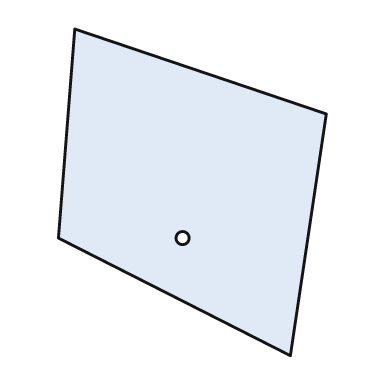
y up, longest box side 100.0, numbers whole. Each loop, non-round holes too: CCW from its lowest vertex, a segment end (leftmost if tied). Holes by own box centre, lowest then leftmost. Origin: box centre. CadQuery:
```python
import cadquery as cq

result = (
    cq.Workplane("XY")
    .moveTo(30.0, -50.0)
    .lineTo(41.0, 24.0)
    .lineTo(-36.0, 50.0)
    .lineTo(-41.0, -14.0)
    .close()
    .moveTo(-3.0, -14.0)
    .circle(2.0)
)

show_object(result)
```